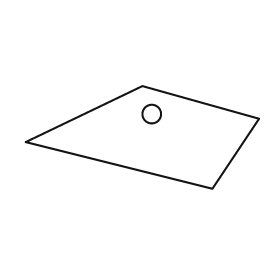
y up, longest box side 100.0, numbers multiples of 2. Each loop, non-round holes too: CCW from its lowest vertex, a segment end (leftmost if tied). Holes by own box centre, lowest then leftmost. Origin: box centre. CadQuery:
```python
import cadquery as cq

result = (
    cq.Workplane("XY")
    .moveTo(30.0, -22.0)
    .lineTo(50.0, 8.0)
    .lineTo(0.0, 22.0)
    .lineTo(-50.0, -2.0)
    .close()
    .moveTo(4.0, 10.0)
    .circle(4.0)
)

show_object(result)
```